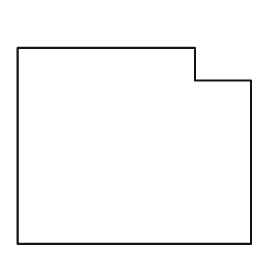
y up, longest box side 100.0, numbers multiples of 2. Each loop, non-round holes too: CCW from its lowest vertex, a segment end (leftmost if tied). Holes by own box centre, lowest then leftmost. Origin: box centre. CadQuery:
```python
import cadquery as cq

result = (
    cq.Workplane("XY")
    .moveTo(-50.0, -42.0)
    .lineTo(50.0, -42.0)
    .lineTo(50.0, 28.0)
    .lineTo(26.0, 28.0)
    .lineTo(26.0, 42.0)
    .lineTo(-50.0, 42.0)
    .close()
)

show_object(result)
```